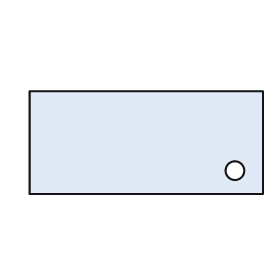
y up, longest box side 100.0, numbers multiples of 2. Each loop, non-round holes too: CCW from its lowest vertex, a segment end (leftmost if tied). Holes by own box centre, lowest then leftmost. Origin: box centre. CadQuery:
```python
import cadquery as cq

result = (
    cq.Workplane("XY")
    .moveTo(-50.0, -22.0)
    .lineTo(50.0, -22.0)
    .lineTo(50.0, 22.0)
    .lineTo(-50.0, 22.0)
    .close()
    .moveTo(38.0, -12.0)
    .circle(4.0)
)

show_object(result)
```